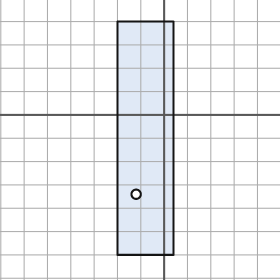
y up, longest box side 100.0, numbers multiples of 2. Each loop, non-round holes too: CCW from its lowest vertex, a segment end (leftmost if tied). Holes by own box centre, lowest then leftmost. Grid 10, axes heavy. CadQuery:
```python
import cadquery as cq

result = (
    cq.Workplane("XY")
    .moveTo(-20.0, -60.0)
    .lineTo(4.0, -60.0)
    .lineTo(4.0, 40.0)
    .lineTo(-20.0, 40.0)
    .close()
    .moveTo(-12.0, -34.0)
    .circle(2.0)
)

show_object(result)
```